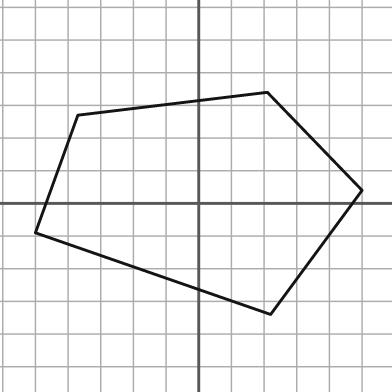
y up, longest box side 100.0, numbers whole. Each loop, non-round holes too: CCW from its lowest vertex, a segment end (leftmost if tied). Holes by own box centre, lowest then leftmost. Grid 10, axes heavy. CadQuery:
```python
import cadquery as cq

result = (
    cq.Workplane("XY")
    .moveTo(22.0, -34.0)
    .lineTo(50.0, 4.0)
    .lineTo(21.0, 34.0)
    .lineTo(-37.0, 27.0)
    .lineTo(-50.0, -9.0)
    .close()
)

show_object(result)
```